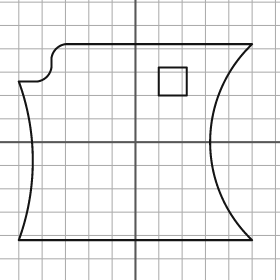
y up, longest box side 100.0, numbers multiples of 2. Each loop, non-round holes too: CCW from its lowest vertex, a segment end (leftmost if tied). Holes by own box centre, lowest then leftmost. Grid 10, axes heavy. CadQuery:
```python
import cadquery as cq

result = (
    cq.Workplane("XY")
    .moveTo(-50.0, -42.0)
    .lineTo(50.0, -42.0)
    .threePointArc((32.0, 0.0), (50.0, 42.0))
    .lineTo(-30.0, 42.0)
    .threePointArc((-34.0, 40.0), (-36.0, 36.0))
    .lineTo(-36.0, 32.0)
    .threePointArc((-38.0, 28.0), (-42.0, 26.0))
    .lineTo(-50.0, 26.0)
    .threePointArc((-44.0, -8.0), (-50.0, -42.0))
    .close()
    .moveTo(10.0, 20.0)
    .lineTo(22.0, 20.0)
    .lineTo(22.0, 32.0)
    .lineTo(10.0, 32.0)
    .close()
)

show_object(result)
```